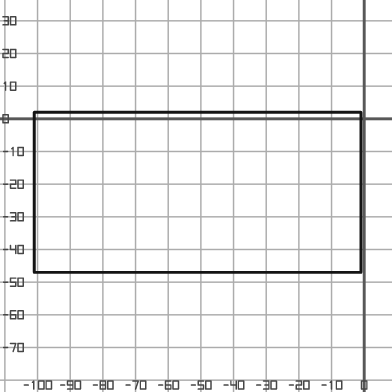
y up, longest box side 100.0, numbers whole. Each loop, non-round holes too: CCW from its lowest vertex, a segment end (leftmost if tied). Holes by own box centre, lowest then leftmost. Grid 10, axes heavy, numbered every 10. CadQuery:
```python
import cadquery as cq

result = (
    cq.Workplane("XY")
    .moveTo(-101.0, -47.0)
    .lineTo(-1.0, -47.0)
    .lineTo(-1.0, 2.0)
    .lineTo(-101.0, 2.0)
    .close()
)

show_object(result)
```